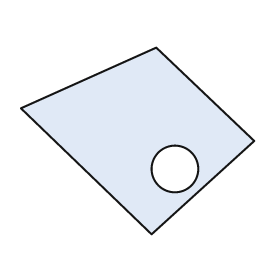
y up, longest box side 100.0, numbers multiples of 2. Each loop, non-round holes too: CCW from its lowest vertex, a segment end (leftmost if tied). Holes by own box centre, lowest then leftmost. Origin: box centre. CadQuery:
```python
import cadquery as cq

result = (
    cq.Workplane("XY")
    .moveTo(6.0, -40.0)
    .lineTo(50.0, 0.0)
    .lineTo(8.0, 40.0)
    .lineTo(-50.0, 14.0)
    .close()
    .moveTo(16.0, -12.0)
    .circle(10.0)
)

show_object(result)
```